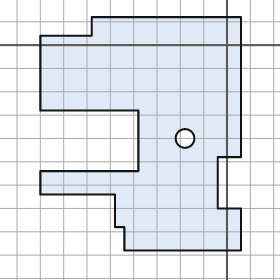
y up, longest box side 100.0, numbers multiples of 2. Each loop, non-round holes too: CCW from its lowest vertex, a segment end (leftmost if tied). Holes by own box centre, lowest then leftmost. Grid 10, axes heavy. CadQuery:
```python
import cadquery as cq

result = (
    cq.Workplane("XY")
    .moveTo(-44.0, -88.0)
    .lineTo(6.0, -88.0)
    .lineTo(6.0, -70.0)
    .lineTo(-4.0, -70.0)
    .lineTo(-4.0, -48.0)
    .lineTo(6.0, -48.0)
    .lineTo(6.0, 12.0)
    .lineTo(-58.0, 12.0)
    .lineTo(-58.0, 4.0)
    .lineTo(-80.0, 4.0)
    .lineTo(-80.0, -28.0)
    .lineTo(-38.0, -28.0)
    .lineTo(-38.0, -54.0)
    .lineTo(-80.0, -54.0)
    .lineTo(-80.0, -64.0)
    .lineTo(-48.0, -64.0)
    .lineTo(-48.0, -78.0)
    .lineTo(-44.0, -78.0)
    .close()
    .moveTo(-18.0, -40.0)
    .circle(4.0)
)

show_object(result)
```